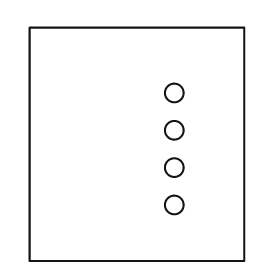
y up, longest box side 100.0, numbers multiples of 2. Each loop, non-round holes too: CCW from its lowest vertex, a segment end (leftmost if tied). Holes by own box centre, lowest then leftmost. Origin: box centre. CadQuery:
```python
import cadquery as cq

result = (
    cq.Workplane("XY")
    .moveTo(-46.0, -50.0)
    .lineTo(46.0, -50.0)
    .lineTo(46.0, 50.0)
    .lineTo(-46.0, 50.0)
    .close()
    .moveTo(16.0, -26.0)
    .circle(4.0)
    .moveTo(16.0, -10.0)
    .circle(4.0)
    .moveTo(16.0, 6.0)
    .circle(4.0)
    .moveTo(16.0, 22.0)
    .circle(4.0)
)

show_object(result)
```